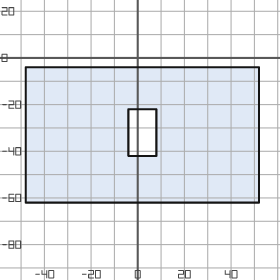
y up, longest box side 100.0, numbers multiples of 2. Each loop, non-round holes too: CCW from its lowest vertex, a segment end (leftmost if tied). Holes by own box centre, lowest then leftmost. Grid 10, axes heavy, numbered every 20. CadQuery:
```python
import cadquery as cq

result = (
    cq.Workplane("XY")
    .moveTo(-48.0, -62.0)
    .lineTo(52.0, -62.0)
    .lineTo(52.0, -4.0)
    .lineTo(-48.0, -4.0)
    .close()
    .moveTo(-4.0, -42.0)
    .lineTo(8.0, -42.0)
    .lineTo(8.0, -22.0)
    .lineTo(-4.0, -22.0)
    .close()
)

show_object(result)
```